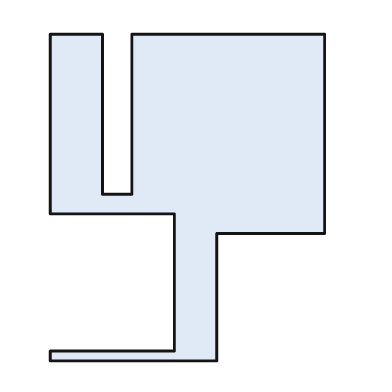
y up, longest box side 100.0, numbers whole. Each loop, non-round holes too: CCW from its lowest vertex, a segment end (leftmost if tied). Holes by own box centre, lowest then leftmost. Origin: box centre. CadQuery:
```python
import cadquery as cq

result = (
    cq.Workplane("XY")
    .moveTo(-42.0, -50.0)
    .lineTo(9.0, -50.0)
    .lineTo(9.0, -11.0)
    .lineTo(42.0, -11.0)
    .lineTo(42.0, 50.0)
    .lineTo(-17.0, 50.0)
    .lineTo(-17.0, 1.0)
    .lineTo(-26.0, 1.0)
    .lineTo(-26.0, 50.0)
    .lineTo(-42.0, 50.0)
    .lineTo(-42.0, -5.0)
    .lineTo(-4.0, -5.0)
    .lineTo(-4.0, -47.0)
    .lineTo(-42.0, -47.0)
    .close()
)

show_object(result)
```